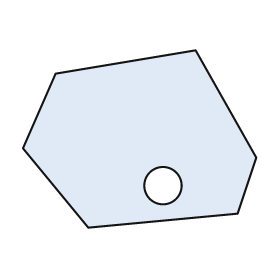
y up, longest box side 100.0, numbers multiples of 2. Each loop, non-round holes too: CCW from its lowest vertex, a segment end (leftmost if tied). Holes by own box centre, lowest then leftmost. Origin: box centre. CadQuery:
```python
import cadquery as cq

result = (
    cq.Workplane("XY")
    .moveTo(-22.0, -38.0)
    .lineTo(42.0, -32.0)
    .lineTo(50.0, -8.0)
    .lineTo(24.0, 38.0)
    .lineTo(-36.0, 28.0)
    .lineTo(-50.0, -4.0)
    .close()
    .moveTo(10.0, -20.0)
    .circle(8.0)
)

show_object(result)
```